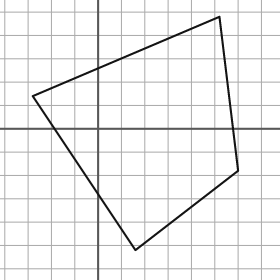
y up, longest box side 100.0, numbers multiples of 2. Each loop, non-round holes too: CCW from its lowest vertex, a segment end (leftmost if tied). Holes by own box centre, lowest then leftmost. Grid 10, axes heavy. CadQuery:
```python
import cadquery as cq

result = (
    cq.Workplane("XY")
    .moveTo(16.0, -52.0)
    .lineTo(60.0, -18.0)
    .lineTo(52.0, 48.0)
    .lineTo(-28.0, 14.0)
    .close()
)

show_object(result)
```